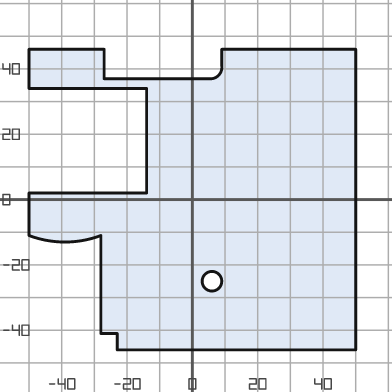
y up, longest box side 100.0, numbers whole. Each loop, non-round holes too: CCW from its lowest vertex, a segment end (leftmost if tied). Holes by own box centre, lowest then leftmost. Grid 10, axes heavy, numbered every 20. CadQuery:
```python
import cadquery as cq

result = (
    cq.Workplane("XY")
    .moveTo(-23.0, -46.0)
    .lineTo(50.0, -46.0)
    .lineTo(50.0, 46.0)
    .lineTo(9.0, 46.0)
    .lineTo(9.0, 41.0)
    .threePointArc((8.0, 38.0), (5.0, 37.0))
    .lineTo(-27.0, 37.0)
    .lineTo(-27.0, 46.0)
    .lineTo(-50.0, 46.0)
    .lineTo(-50.0, 34.0)
    .lineTo(-14.0, 34.0)
    .lineTo(-14.0, 2.0)
    .lineTo(-50.0, 2.0)
    .lineTo(-50.0, -11.0)
    .threePointArc((-39.0, -13.0), (-28.0, -11.0))
    .lineTo(-28.0, -41.0)
    .lineTo(-23.0, -41.0)
    .close()
    .moveTo(6.0, -25.0)
    .circle(3.0)
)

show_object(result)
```